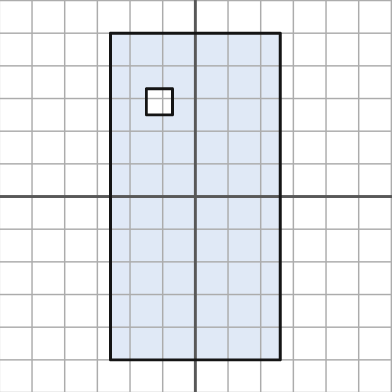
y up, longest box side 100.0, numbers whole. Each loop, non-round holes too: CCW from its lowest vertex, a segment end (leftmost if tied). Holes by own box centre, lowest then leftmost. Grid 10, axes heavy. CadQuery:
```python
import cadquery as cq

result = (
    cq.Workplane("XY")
    .moveTo(-26.0, -50.0)
    .lineTo(26.0, -50.0)
    .lineTo(26.0, 50.0)
    .lineTo(-26.0, 50.0)
    .close()
    .moveTo(-15.0, 25.0)
    .lineTo(-7.0, 25.0)
    .lineTo(-7.0, 33.0)
    .lineTo(-15.0, 33.0)
    .close()
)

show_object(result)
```